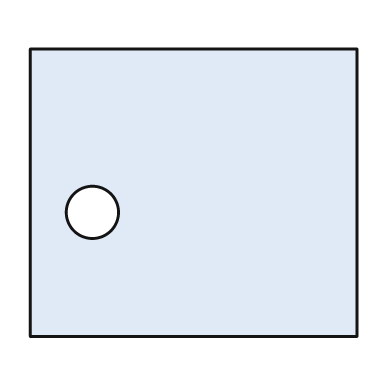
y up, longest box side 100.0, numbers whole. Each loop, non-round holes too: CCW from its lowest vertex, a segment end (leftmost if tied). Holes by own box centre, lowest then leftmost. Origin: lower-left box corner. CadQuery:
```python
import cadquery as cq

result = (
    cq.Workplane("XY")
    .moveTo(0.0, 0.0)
    .lineTo(100.0, 0.0)
    .lineTo(100.0, 88.0)
    .lineTo(0.0, 88.0)
    .close()
    .moveTo(19.0, 38.0)
    .circle(8.0)
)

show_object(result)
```